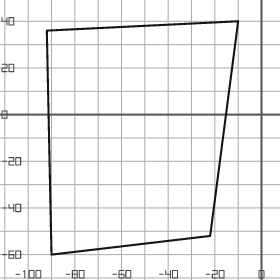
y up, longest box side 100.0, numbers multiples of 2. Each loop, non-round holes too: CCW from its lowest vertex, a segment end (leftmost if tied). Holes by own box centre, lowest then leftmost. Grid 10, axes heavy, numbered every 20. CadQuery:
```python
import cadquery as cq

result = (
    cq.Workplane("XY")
    .moveTo(-90.0, -60.0)
    .lineTo(-22.0, -52.0)
    .lineTo(-10.0, 40.0)
    .lineTo(-92.0, 36.0)
    .close()
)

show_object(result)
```